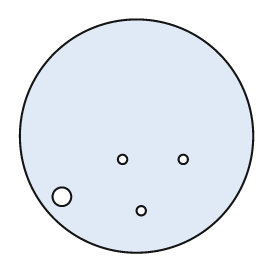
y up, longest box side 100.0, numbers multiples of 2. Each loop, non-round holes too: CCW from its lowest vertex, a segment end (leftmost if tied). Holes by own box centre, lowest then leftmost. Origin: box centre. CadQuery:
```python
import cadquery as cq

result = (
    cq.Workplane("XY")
    .moveTo(0.0, 0.0)
    .circle(50.0)
    .moveTo(2.0, -32.0)
    .circle(2.0)
    .moveTo(-32.0, -26.0)
    .circle(4.0)
    .moveTo(-6.0, -10.0)
    .circle(2.0)
    .moveTo(20.0, -10.0)
    .circle(2.0)
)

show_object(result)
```